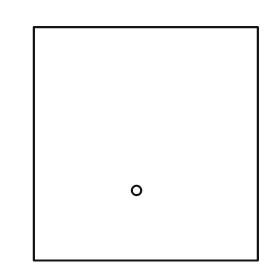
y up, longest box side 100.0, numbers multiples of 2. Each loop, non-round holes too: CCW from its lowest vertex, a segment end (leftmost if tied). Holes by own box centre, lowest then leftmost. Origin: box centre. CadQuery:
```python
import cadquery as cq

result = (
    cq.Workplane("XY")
    .moveTo(-48.0, -50.0)
    .lineTo(48.0, -50.0)
    .lineTo(48.0, 50.0)
    .lineTo(-48.0, 50.0)
    .close()
    .moveTo(-4.0, -20.0)
    .circle(2.0)
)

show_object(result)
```